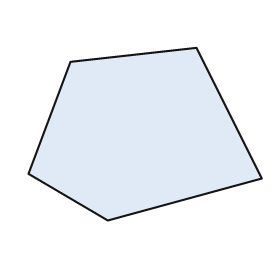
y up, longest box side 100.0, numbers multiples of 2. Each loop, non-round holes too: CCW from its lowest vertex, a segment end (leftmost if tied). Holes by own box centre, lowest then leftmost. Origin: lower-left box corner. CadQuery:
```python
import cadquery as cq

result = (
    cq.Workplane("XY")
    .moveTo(34.0, 0.0)
    .lineTo(100.0, 18.0)
    .lineTo(72.0, 74.0)
    .lineTo(18.0, 68.0)
    .lineTo(0.0, 20.0)
    .close()
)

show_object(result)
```